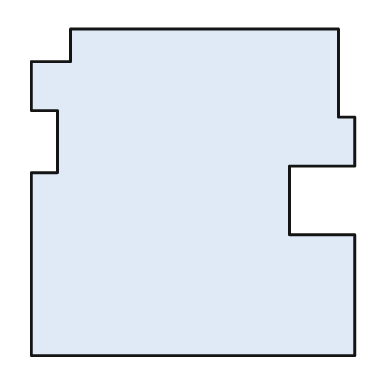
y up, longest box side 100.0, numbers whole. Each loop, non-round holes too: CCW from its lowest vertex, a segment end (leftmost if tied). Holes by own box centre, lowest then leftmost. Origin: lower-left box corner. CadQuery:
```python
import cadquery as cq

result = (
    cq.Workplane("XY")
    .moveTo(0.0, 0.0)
    .lineTo(99.0, 0.0)
    .lineTo(99.0, 37.0)
    .lineTo(79.0, 37.0)
    .lineTo(79.0, 58.0)
    .lineTo(99.0, 58.0)
    .lineTo(99.0, 73.0)
    .lineTo(94.0, 73.0)
    .lineTo(94.0, 100.0)
    .lineTo(12.0, 100.0)
    .lineTo(12.0, 90.0)
    .lineTo(0.0, 90.0)
    .lineTo(0.0, 75.0)
    .lineTo(8.0, 75.0)
    .lineTo(8.0, 56.0)
    .lineTo(0.0, 56.0)
    .close()
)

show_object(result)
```